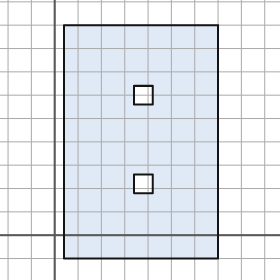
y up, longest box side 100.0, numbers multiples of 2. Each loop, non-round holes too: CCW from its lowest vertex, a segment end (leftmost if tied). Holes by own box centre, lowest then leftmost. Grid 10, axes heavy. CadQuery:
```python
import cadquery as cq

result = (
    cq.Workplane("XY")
    .moveTo(4.0, -10.0)
    .lineTo(70.0, -10.0)
    .lineTo(70.0, 90.0)
    .lineTo(4.0, 90.0)
    .close()
    .moveTo(34.0, 18.0)
    .lineTo(42.0, 18.0)
    .lineTo(42.0, 26.0)
    .lineTo(34.0, 26.0)
    .close()
    .moveTo(34.0, 56.0)
    .lineTo(42.0, 56.0)
    .lineTo(42.0, 64.0)
    .lineTo(34.0, 64.0)
    .close()
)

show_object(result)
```